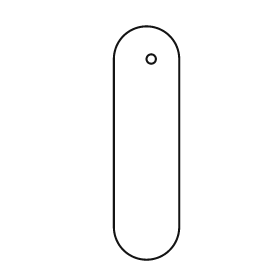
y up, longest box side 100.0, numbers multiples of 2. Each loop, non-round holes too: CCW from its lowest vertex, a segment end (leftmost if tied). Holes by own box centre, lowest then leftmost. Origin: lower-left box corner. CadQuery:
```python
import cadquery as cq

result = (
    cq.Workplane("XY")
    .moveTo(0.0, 14.0)
    .threePointArc((14.0, 0.0), (28.0, 14.0))
    .lineTo(28.0, 86.0)
    .threePointArc((14.0, 100.0), (0.0, 86.0))
    .close()
    .moveTo(16.0, 86.0)
    .circle(2.0)
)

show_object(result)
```